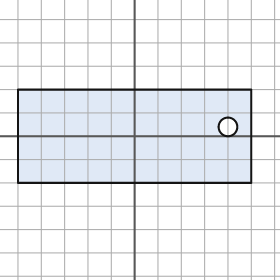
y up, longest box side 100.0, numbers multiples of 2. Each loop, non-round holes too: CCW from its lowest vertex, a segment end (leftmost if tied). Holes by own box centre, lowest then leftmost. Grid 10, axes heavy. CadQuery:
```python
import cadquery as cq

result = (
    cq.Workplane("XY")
    .moveTo(-50.0, -20.0)
    .lineTo(50.0, -20.0)
    .lineTo(50.0, 20.0)
    .lineTo(-50.0, 20.0)
    .close()
    .moveTo(40.0, 4.0)
    .circle(4.0)
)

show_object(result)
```